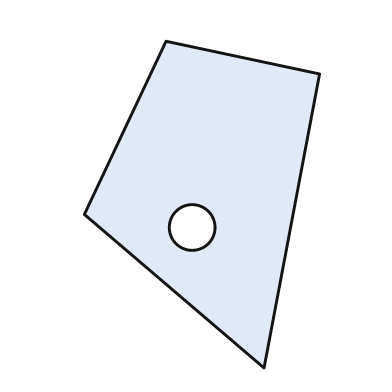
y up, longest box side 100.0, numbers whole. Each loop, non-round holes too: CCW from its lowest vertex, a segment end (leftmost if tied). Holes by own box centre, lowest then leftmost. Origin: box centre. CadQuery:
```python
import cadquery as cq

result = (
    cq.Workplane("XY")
    .moveTo(19.0, -50.0)
    .lineTo(36.0, 40.0)
    .lineTo(-11.0, 50.0)
    .lineTo(-36.0, -3.0)
    .close()
    .moveTo(-3.0, -7.0)
    .circle(7.0)
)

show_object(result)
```